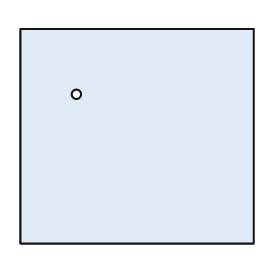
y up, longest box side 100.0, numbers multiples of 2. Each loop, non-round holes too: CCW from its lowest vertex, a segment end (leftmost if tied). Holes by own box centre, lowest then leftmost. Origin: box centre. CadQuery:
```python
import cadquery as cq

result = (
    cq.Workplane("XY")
    .moveTo(-50.0, -46.0)
    .lineTo(50.0, -46.0)
    .lineTo(50.0, 46.0)
    .lineTo(-50.0, 46.0)
    .close()
    .moveTo(-26.0, 18.0)
    .circle(2.0)
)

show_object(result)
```